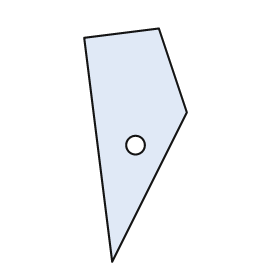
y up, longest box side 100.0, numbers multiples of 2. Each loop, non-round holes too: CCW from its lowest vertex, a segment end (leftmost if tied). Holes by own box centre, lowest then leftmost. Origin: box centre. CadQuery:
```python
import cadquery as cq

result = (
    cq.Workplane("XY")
    .moveTo(-10.0, -50.0)
    .lineTo(22.0, 14.0)
    .lineTo(10.0, 50.0)
    .lineTo(-22.0, 46.0)
    .close()
    .moveTo(0.0, 0.0)
    .circle(4.0)
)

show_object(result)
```